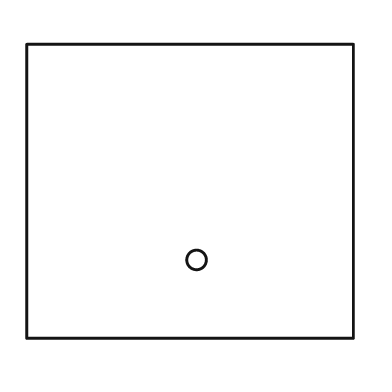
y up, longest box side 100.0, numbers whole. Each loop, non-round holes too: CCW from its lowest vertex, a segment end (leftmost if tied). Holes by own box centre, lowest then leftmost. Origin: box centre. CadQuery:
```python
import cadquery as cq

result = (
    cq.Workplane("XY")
    .moveTo(-50.0, -45.0)
    .lineTo(50.0, -45.0)
    .lineTo(50.0, 45.0)
    .lineTo(-50.0, 45.0)
    .close()
    .moveTo(2.0, -21.0)
    .circle(3.0)
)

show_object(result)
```